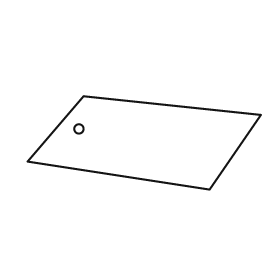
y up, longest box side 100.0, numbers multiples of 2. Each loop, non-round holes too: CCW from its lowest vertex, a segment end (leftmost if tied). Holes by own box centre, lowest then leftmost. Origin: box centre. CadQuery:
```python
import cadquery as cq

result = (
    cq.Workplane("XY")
    .moveTo(28.0, -20.0)
    .lineTo(50.0, 12.0)
    .lineTo(-26.0, 20.0)
    .lineTo(-50.0, -8.0)
    .close()
    .moveTo(-28.0, 6.0)
    .circle(2.0)
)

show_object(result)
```